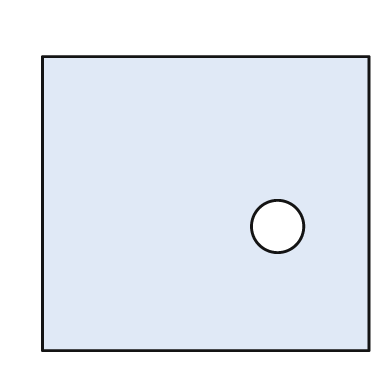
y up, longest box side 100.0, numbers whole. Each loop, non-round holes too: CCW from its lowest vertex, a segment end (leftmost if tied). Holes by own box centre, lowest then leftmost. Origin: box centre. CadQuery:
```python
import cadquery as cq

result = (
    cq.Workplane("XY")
    .moveTo(-50.0, -45.0)
    .lineTo(50.0, -45.0)
    .lineTo(50.0, 45.0)
    .lineTo(-50.0, 45.0)
    .close()
    .moveTo(22.0, -7.0)
    .circle(8.0)
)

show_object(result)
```